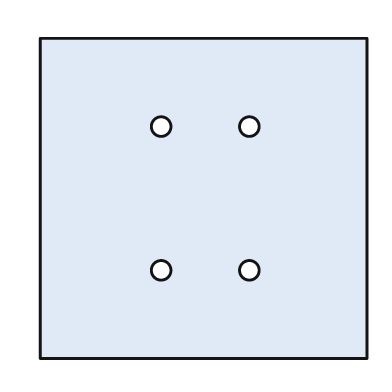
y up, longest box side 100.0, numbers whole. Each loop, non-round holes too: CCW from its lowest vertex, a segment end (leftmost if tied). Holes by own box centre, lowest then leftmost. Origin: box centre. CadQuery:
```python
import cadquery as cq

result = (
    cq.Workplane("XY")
    .moveTo(-50.0, -49.0)
    .lineTo(50.0, -49.0)
    .lineTo(50.0, 49.0)
    .lineTo(-50.0, 49.0)
    .close()
    .moveTo(-13.0, -22.0)
    .circle(3.0)
    .moveTo(14.0, -22.0)
    .circle(3.0)
    .moveTo(-13.0, 22.0)
    .circle(3.0)
    .moveTo(14.0, 22.0)
    .circle(3.0)
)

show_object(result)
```